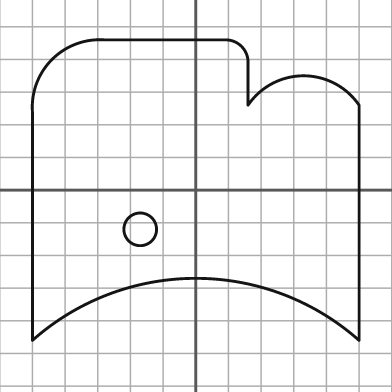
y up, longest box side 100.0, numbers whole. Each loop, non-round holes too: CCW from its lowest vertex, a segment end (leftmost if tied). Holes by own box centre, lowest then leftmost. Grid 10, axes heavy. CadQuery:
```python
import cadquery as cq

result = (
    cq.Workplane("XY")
    .moveTo(-50.0, -46.0)
    .threePointArc((0.0, -27.0), (50.0, -46.0))
    .lineTo(50.0, 26.0)
    .threePointArc((33.0, 35.0), (16.0, 26.0))
    .lineTo(16.0, 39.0)
    .threePointArc((14.0, 44.0), (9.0, 46.0))
    .lineTo(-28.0, 46.0)
    .threePointArc((-44.0, 40.0), (-50.0, 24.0))
    .close()
    .moveTo(-17.0, -12.0)
    .circle(5.0)
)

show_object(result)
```